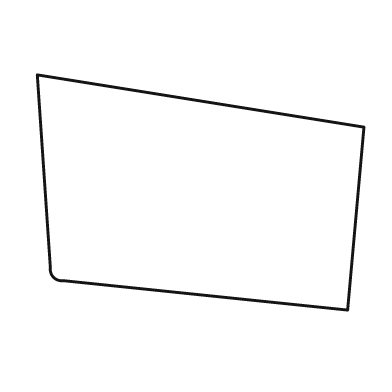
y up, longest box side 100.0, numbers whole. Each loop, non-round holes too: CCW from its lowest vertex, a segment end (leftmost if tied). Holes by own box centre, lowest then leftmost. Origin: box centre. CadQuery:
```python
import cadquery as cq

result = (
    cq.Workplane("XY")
    .moveTo(45.0, -36.0)
    .lineTo(50.0, 20.0)
    .lineTo(-50.0, 36.0)
    .lineTo(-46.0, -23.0)
    .threePointArc((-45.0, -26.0), (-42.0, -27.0))
    .close()
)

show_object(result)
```